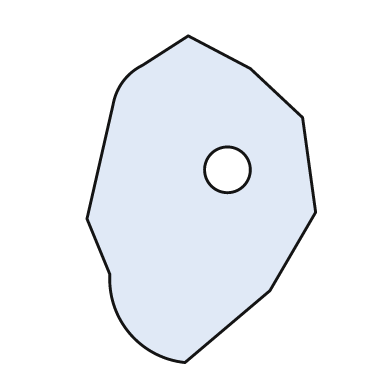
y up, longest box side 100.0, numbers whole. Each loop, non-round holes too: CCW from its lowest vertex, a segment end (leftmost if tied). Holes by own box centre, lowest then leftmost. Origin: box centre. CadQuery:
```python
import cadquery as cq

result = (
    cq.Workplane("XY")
    .moveTo(-5.0, -50.0)
    .lineTo(21.0, -28.0)
    .lineTo(35.0, -4.0)
    .lineTo(31.0, 25.0)
    .lineTo(15.0, 40.0)
    .lineTo(-4.0, 50.0)
    .lineTo(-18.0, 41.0)
    .threePointArc((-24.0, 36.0), (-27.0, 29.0))
    .lineTo(-35.0, -6.0)
    .lineTo(-28.0, -23.0)
    .threePointArc((-22.0, -41.0), (-5.0, -50.0))
    .close()
    .moveTo(8.0, 9.0)
    .circle(7.0)
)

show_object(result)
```